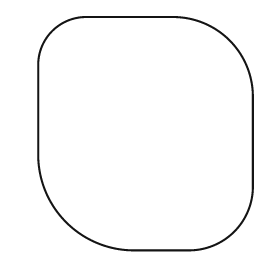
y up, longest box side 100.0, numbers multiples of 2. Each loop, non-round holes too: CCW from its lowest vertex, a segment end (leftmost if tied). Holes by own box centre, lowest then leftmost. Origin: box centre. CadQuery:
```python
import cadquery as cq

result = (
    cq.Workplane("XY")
    .moveTo(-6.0, -50.0)
    .lineTo(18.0, -50.0)
    .threePointArc((38.0, -42.0), (46.0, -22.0))
    .lineTo(46.0, 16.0)
    .threePointArc((36.0, 40.0), (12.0, 50.0))
    .lineTo(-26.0, 50.0)
    .threePointArc((-40.0, 44.0), (-46.0, 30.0))
    .lineTo(-46.0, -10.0)
    .threePointArc((-34.0, -38.0), (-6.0, -50.0))
    .close()
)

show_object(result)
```